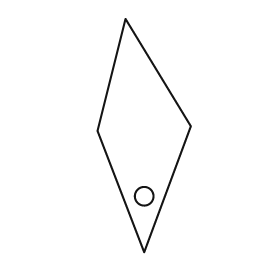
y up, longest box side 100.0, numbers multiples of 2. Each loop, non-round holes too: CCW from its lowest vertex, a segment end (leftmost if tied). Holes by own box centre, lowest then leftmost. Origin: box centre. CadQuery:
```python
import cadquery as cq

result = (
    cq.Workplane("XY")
    .moveTo(0.0, -50.0)
    .lineTo(20.0, 4.0)
    .lineTo(-8.0, 50.0)
    .lineTo(-20.0, 2.0)
    .close()
    .moveTo(0.0, -26.0)
    .circle(4.0)
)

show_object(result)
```